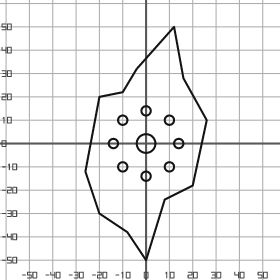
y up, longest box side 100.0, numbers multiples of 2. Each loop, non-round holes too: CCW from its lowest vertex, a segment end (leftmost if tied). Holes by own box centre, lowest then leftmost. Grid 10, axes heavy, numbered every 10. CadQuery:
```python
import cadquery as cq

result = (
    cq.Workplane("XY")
    .moveTo(0.0, -50.0)
    .lineTo(8.0, -24.0)
    .lineTo(20.0, -18.0)
    .lineTo(26.0, 10.0)
    .lineTo(16.0, 28.0)
    .lineTo(12.0, 50.0)
    .lineTo(-4.0, 32.0)
    .lineTo(-10.0, 22.0)
    .lineTo(-20.0, 20.0)
    .lineTo(-26.0, -12.0)
    .lineTo(-20.0, -30.0)
    .lineTo(-8.0, -38.0)
    .close()
    .moveTo(0.0, -14.0)
    .circle(2.0)
    .moveTo(-10.0, -10.0)
    .circle(2.0)
    .moveTo(10.0, -10.0)
    .circle(2.0)
    .moveTo(-14.0, 0.0)
    .circle(2.0)
    .moveTo(0.0, 0.0)
    .circle(4.0)
    .moveTo(14.0, 0.0)
    .circle(2.0)
    .moveTo(-10.0, 10.0)
    .circle(2.0)
    .moveTo(10.0, 10.0)
    .circle(2.0)
    .moveTo(0.0, 14.0)
    .circle(2.0)
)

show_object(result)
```